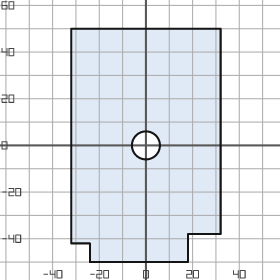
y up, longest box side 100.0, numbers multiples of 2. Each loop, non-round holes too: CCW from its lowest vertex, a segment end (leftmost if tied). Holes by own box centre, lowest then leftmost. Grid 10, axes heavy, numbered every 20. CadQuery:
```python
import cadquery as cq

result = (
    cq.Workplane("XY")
    .moveTo(-24.0, -50.0)
    .lineTo(18.0, -50.0)
    .lineTo(18.0, -38.0)
    .lineTo(32.0, -38.0)
    .lineTo(32.0, 50.0)
    .lineTo(-32.0, 50.0)
    .lineTo(-32.0, -42.0)
    .lineTo(-24.0, -42.0)
    .close()
    .moveTo(0.0, 0.0)
    .circle(6.0)
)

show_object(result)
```